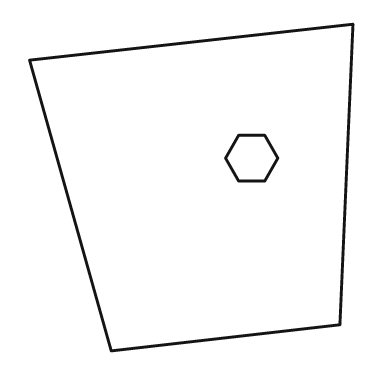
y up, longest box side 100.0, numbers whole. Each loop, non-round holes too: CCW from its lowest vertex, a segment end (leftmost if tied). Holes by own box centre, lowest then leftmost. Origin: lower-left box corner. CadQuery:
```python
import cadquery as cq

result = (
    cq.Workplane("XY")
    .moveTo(25.0, 0.0)
    .lineTo(95.0, 8.0)
    .lineTo(99.0, 100.0)
    .lineTo(0.0, 89.0)
    .close()
    .moveTo(64.0, 52.0)
    .lineTo(72.0, 52.0)
    .lineTo(76.0, 59.0)
    .lineTo(72.0, 66.0)
    .lineTo(64.0, 66.0)
    .lineTo(60.0, 59.0)
    .close()
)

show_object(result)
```